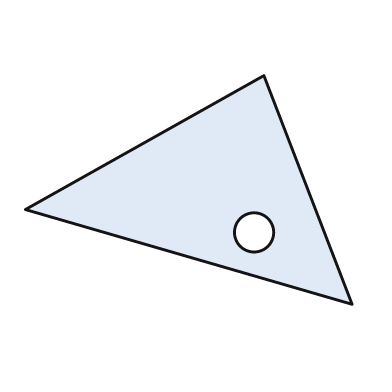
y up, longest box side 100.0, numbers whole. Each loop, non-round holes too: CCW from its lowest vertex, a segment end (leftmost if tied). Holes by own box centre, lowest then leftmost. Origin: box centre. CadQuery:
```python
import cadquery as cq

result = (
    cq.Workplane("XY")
    .moveTo(50.0, -35.0)
    .lineTo(23.0, 35.0)
    .lineTo(-50.0, -6.0)
    .close()
    .moveTo(20.0, -13.0)
    .circle(6.0)
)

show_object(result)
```